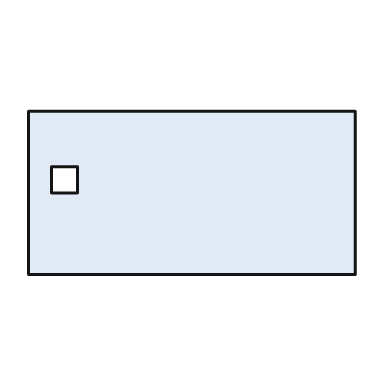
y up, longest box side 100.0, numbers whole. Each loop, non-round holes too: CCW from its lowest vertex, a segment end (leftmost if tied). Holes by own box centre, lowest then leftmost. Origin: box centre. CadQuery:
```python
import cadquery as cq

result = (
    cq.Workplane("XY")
    .moveTo(-50.0, -25.0)
    .lineTo(50.0, -25.0)
    .lineTo(50.0, 25.0)
    .lineTo(-50.0, 25.0)
    .close()
    .moveTo(-43.0, 0.0)
    .lineTo(-35.0, 0.0)
    .lineTo(-35.0, 8.0)
    .lineTo(-43.0, 8.0)
    .close()
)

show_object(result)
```